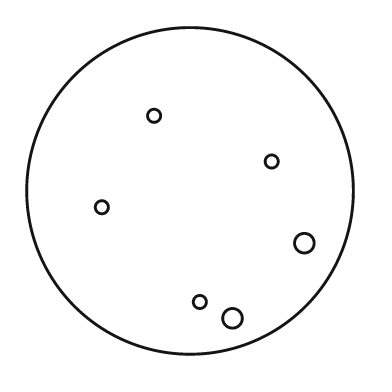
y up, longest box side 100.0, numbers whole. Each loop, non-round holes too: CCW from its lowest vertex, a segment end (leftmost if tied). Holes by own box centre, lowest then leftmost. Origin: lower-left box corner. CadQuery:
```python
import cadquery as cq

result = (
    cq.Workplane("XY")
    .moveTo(50.0, 50.0)
    .circle(50.0)
    .moveTo(63.0, 11.0)
    .circle(3.0)
    .moveTo(53.0, 16.0)
    .circle(2.0)
    .moveTo(85.0, 34.0)
    .circle(3.0)
    .moveTo(23.0, 45.0)
    .circle(2.0)
    .moveTo(75.0, 59.0)
    .circle(2.0)
    .moveTo(39.0, 73.0)
    .circle(2.0)
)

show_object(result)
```